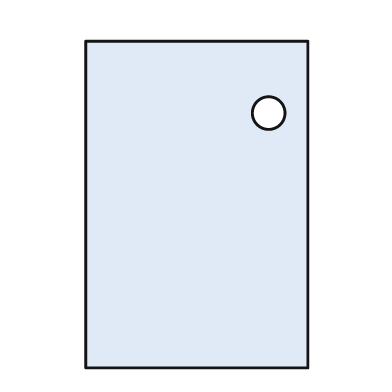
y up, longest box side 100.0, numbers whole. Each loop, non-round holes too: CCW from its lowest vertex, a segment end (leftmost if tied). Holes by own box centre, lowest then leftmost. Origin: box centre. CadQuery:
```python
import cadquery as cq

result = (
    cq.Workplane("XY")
    .moveTo(-34.0, -50.0)
    .lineTo(34.0, -50.0)
    .lineTo(34.0, 50.0)
    .lineTo(-34.0, 50.0)
    .close()
    .moveTo(22.0, 28.0)
    .circle(5.0)
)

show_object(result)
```